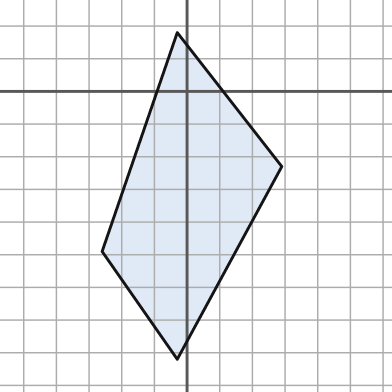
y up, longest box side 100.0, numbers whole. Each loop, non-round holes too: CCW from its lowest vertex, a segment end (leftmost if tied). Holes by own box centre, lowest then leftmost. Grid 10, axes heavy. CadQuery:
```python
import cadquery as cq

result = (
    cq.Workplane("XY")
    .moveTo(-3.0, -82.0)
    .lineTo(29.0, -23.0)
    .lineTo(-3.0, 18.0)
    .lineTo(-26.0, -49.0)
    .close()
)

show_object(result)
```